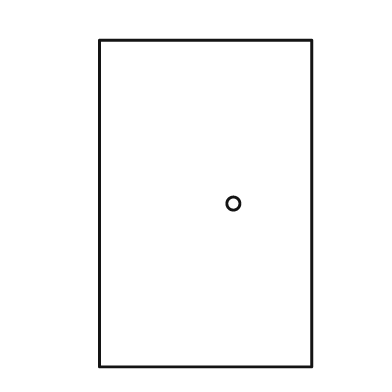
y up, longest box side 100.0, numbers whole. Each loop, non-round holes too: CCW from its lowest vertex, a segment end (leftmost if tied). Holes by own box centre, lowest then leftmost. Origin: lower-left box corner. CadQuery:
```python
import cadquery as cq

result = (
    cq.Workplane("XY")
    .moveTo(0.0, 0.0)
    .lineTo(65.0, 0.0)
    .lineTo(65.0, 100.0)
    .lineTo(0.0, 100.0)
    .close()
    .moveTo(41.0, 50.0)
    .circle(2.0)
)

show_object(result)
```